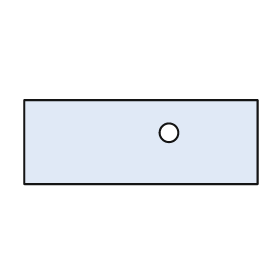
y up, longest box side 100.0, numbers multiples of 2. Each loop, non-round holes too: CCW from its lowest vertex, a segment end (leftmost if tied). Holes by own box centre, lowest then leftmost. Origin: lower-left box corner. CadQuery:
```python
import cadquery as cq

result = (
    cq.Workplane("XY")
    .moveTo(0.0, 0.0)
    .lineTo(100.0, 0.0)
    .lineTo(100.0, 36.0)
    .lineTo(0.0, 36.0)
    .close()
    .moveTo(62.0, 22.0)
    .circle(4.0)
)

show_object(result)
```